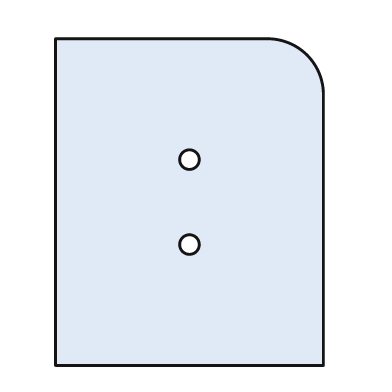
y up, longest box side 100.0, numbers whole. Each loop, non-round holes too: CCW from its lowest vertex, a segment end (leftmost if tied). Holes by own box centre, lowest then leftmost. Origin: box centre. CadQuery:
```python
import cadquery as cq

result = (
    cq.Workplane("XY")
    .moveTo(-41.0, -50.0)
    .lineTo(41.0, -50.0)
    .lineTo(41.0, 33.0)
    .threePointArc((36.0, 45.0), (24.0, 50.0))
    .lineTo(-41.0, 50.0)
    .close()
    .moveTo(0.0, -13.0)
    .circle(3.0)
    .moveTo(0.0, 13.0)
    .circle(3.0)
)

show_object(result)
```